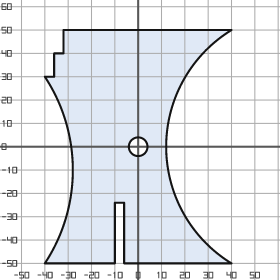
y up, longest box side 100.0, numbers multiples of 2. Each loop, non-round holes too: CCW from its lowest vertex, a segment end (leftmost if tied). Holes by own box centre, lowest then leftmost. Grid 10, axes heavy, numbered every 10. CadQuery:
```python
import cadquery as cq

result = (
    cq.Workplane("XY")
    .moveTo(-40.0, -50.0)
    .lineTo(-10.0, -50.0)
    .lineTo(-10.0, -24.0)
    .lineTo(-6.0, -24.0)
    .lineTo(-6.0, -50.0)
    .lineTo(40.0, -50.0)
    .threePointArc((12.0, 0.0), (40.0, 50.0))
    .lineTo(-32.0, 50.0)
    .lineTo(-32.0, 40.0)
    .lineTo(-36.0, 40.0)
    .lineTo(-36.0, 30.0)
    .lineTo(-40.0, 30.0)
    .threePointArc((-28.0, -10.0), (-40.0, -50.0))
    .close()
    .moveTo(0.0, 0.0)
    .circle(4.0)
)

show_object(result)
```